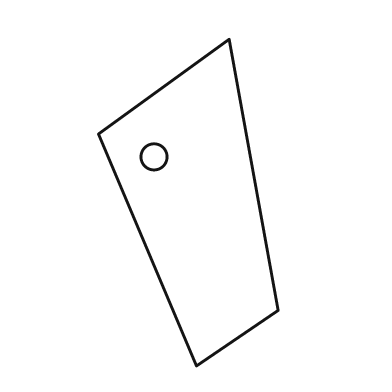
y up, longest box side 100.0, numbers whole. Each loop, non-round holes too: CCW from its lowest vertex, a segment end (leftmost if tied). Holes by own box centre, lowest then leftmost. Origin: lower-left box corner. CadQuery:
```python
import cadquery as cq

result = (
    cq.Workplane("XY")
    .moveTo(30.0, 0.0)
    .lineTo(55.0, 17.0)
    .lineTo(40.0, 100.0)
    .lineTo(0.0, 71.0)
    .close()
    .moveTo(17.0, 64.0)
    .circle(4.0)
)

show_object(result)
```